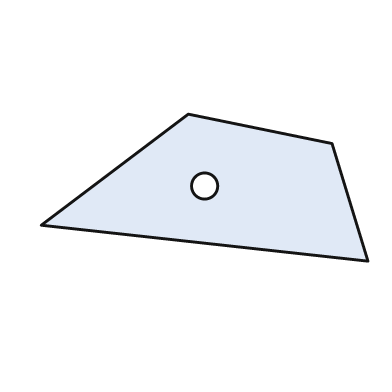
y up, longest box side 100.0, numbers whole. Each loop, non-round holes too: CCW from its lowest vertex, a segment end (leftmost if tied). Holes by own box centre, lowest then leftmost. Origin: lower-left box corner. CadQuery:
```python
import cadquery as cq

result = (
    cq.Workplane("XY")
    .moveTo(100.0, 0.0)
    .lineTo(89.0, 36.0)
    .lineTo(45.0, 45.0)
    .lineTo(0.0, 11.0)
    .close()
    .moveTo(50.0, 23.0)
    .circle(4.0)
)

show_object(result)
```